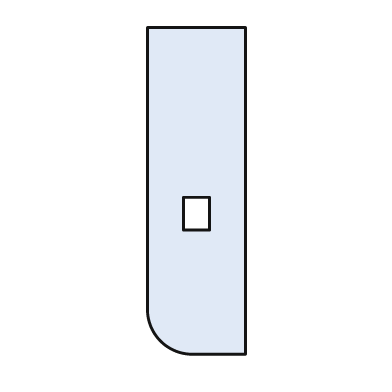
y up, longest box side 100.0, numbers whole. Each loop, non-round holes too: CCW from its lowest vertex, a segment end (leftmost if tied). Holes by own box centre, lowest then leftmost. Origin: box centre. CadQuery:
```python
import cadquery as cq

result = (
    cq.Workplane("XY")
    .moveTo(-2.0, -50.0)
    .lineTo(15.0, -50.0)
    .lineTo(15.0, 50.0)
    .lineTo(-15.0, 50.0)
    .lineTo(-15.0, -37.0)
    .threePointArc((-11.0, -46.0), (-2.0, -50.0))
    .close()
    .moveTo(-4.0, -12.0)
    .lineTo(4.0, -12.0)
    .lineTo(4.0, -2.0)
    .lineTo(-4.0, -2.0)
    .close()
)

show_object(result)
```